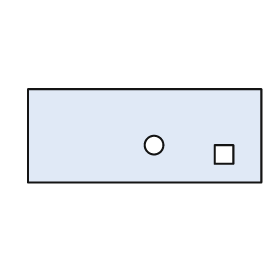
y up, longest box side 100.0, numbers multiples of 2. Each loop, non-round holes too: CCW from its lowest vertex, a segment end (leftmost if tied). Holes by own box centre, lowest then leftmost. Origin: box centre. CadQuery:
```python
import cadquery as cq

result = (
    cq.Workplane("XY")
    .moveTo(-50.0, -20.0)
    .lineTo(50.0, -20.0)
    .lineTo(50.0, 20.0)
    .lineTo(-50.0, 20.0)
    .close()
    .moveTo(30.0, -12.0)
    .lineTo(38.0, -12.0)
    .lineTo(38.0, -4.0)
    .lineTo(30.0, -4.0)
    .close()
    .moveTo(4.0, -4.0)
    .circle(4.0)
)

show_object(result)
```